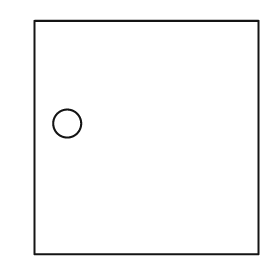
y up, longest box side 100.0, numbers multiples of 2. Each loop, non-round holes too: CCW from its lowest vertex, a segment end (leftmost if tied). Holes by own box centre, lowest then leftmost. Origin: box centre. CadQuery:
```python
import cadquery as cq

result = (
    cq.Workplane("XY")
    .moveTo(-48.0, -50.0)
    .lineTo(48.0, -50.0)
    .lineTo(48.0, 50.0)
    .lineTo(-48.0, 50.0)
    .close()
    .moveTo(-34.0, 6.0)
    .circle(6.0)
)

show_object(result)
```